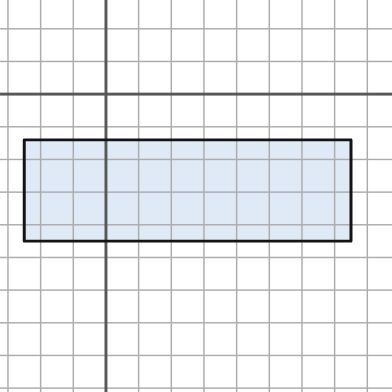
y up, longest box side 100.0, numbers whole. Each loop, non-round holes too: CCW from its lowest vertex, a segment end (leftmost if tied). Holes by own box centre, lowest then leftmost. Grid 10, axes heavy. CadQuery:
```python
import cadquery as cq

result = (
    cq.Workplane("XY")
    .moveTo(-25.0, -45.0)
    .lineTo(75.0, -45.0)
    .lineTo(75.0, -14.0)
    .lineTo(-25.0, -14.0)
    .close()
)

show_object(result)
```